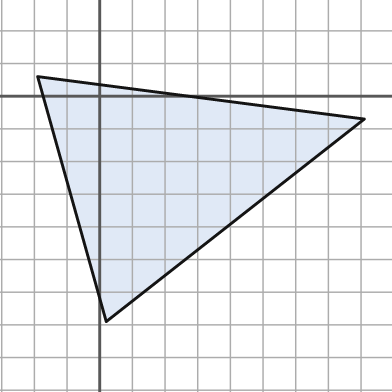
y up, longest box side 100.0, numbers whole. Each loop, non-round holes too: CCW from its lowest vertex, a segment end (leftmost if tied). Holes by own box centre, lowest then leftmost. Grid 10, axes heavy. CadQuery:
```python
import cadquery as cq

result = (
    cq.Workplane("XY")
    .moveTo(2.0, -69.0)
    .lineTo(81.0, -7.0)
    .lineTo(-19.0, 6.0)
    .close()
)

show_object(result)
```